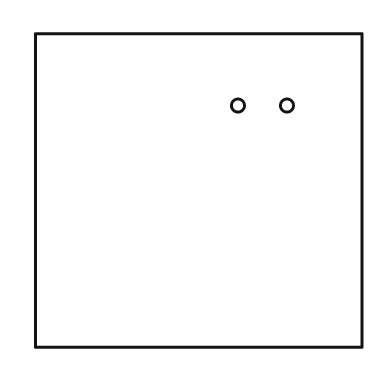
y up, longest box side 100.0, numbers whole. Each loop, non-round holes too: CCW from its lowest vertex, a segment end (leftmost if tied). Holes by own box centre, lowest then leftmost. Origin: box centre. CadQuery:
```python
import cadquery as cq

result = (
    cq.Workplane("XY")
    .moveTo(-50.0, -48.0)
    .lineTo(50.0, -48.0)
    .lineTo(50.0, 48.0)
    .lineTo(-50.0, 48.0)
    .close()
    .moveTo(12.0, 26.0)
    .circle(2.0)
    .moveTo(27.0, 26.0)
    .circle(2.0)
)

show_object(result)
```